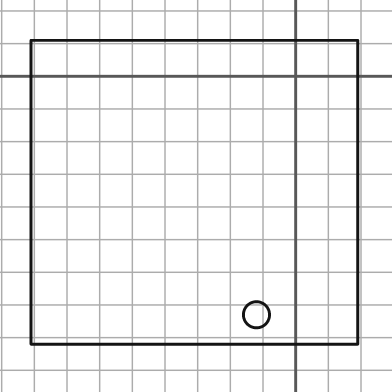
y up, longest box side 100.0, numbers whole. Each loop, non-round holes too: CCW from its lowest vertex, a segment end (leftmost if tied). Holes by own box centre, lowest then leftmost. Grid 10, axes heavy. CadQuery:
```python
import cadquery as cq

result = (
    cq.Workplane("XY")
    .moveTo(-81.0, -82.0)
    .lineTo(19.0, -82.0)
    .lineTo(19.0, 11.0)
    .lineTo(-81.0, 11.0)
    .close()
    .moveTo(-12.0, -73.0)
    .circle(4.0)
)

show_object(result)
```